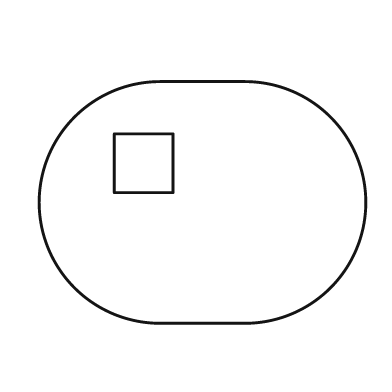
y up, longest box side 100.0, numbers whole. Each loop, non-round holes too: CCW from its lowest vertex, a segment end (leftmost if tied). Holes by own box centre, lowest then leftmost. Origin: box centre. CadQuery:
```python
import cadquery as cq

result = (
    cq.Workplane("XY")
    .moveTo(-13.0, -37.0)
    .lineTo(13.0, -37.0)
    .threePointArc((50.0, 0.0), (13.0, 37.0))
    .lineTo(-13.0, 37.0)
    .threePointArc((-50.0, 0.0), (-13.0, -37.0))
    .close()
    .moveTo(-27.0, 3.0)
    .lineTo(-9.0, 3.0)
    .lineTo(-9.0, 21.0)
    .lineTo(-27.0, 21.0)
    .close()
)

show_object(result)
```